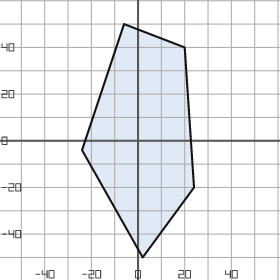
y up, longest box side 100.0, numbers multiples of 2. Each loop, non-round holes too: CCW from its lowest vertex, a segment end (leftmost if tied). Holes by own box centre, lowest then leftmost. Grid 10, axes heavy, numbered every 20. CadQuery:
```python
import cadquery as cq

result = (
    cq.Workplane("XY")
    .moveTo(2.0, -50.0)
    .lineTo(24.0, -20.0)
    .lineTo(20.0, 40.0)
    .lineTo(-6.0, 50.0)
    .lineTo(-24.0, -4.0)
    .close()
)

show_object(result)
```